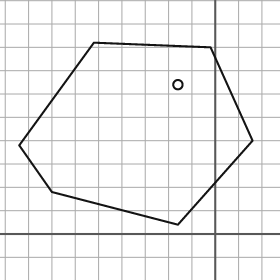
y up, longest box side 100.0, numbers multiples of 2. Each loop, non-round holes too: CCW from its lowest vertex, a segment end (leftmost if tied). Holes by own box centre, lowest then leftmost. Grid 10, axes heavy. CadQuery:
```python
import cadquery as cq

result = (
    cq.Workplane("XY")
    .moveTo(-16.0, 4.0)
    .lineTo(16.0, 40.0)
    .lineTo(-2.0, 80.0)
    .lineTo(-52.0, 82.0)
    .lineTo(-84.0, 38.0)
    .lineTo(-70.0, 18.0)
    .close()
    .moveTo(-16.0, 64.0)
    .circle(2.0)
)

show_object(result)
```